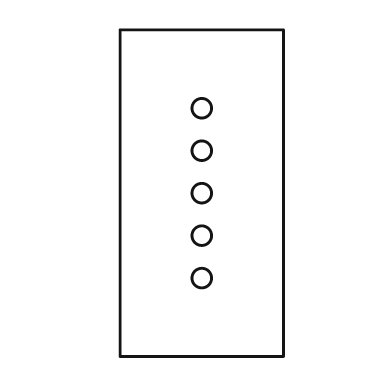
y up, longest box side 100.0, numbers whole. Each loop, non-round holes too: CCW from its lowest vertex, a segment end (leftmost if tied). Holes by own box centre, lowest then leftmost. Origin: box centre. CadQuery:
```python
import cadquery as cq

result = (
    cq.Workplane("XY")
    .moveTo(-25.0, -50.0)
    .lineTo(25.0, -50.0)
    .lineTo(25.0, 50.0)
    .lineTo(-25.0, 50.0)
    .close()
    .moveTo(0.0, -26.0)
    .circle(3.0)
    .moveTo(0.0, -13.0)
    .circle(3.0)
    .moveTo(0.0, 0.0)
    .circle(3.0)
    .moveTo(0.0, 13.0)
    .circle(3.0)
    .moveTo(0.0, 26.0)
    .circle(3.0)
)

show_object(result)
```